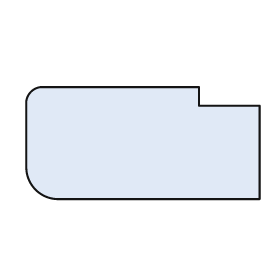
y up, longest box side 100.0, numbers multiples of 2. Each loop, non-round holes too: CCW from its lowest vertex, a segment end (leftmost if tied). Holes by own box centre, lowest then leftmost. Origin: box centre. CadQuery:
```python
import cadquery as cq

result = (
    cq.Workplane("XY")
    .moveTo(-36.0, -24.0)
    .lineTo(50.0, -24.0)
    .lineTo(50.0, 16.0)
    .lineTo(24.0, 16.0)
    .lineTo(24.0, 24.0)
    .lineTo(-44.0, 24.0)
    .threePointArc((-48.0, 22.0), (-50.0, 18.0))
    .lineTo(-50.0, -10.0)
    .threePointArc((-46.0, -20.0), (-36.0, -24.0))
    .close()
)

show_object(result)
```